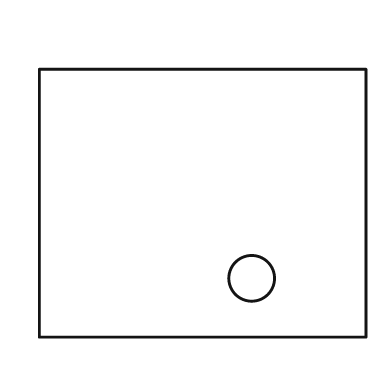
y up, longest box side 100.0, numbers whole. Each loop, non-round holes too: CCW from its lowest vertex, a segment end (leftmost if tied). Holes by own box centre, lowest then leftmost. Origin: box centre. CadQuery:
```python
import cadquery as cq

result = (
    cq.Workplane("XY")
    .moveTo(-50.0, -41.0)
    .lineTo(50.0, -41.0)
    .lineTo(50.0, 41.0)
    .lineTo(-50.0, 41.0)
    .close()
    .moveTo(15.0, -23.0)
    .circle(7.0)
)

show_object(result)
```